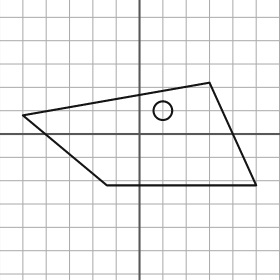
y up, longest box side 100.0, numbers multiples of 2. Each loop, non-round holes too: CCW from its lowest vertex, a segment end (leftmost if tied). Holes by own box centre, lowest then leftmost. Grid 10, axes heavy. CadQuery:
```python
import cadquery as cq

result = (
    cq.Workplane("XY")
    .moveTo(-14.0, -22.0)
    .lineTo(50.0, -22.0)
    .lineTo(30.0, 22.0)
    .lineTo(-50.0, 8.0)
    .close()
    .moveTo(10.0, 10.0)
    .circle(4.0)
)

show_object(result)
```